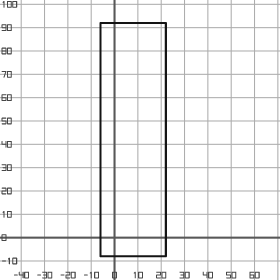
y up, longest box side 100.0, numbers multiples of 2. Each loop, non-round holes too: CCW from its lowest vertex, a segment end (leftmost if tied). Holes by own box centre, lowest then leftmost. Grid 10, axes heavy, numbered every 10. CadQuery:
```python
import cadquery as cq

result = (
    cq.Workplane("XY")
    .moveTo(-6.0, -8.0)
    .lineTo(22.0, -8.0)
    .lineTo(22.0, 92.0)
    .lineTo(-6.0, 92.0)
    .close()
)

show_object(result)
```